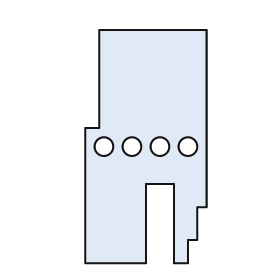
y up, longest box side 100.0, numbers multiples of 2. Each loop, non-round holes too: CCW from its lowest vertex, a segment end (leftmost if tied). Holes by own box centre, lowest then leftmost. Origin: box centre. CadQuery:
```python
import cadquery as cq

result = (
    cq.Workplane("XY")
    .moveTo(-26.0, -50.0)
    .lineTo(0.0, -50.0)
    .lineTo(0.0, -16.0)
    .lineTo(12.0, -16.0)
    .lineTo(12.0, -50.0)
    .lineTo(18.0, -50.0)
    .lineTo(18.0, -40.0)
    .lineTo(22.0, -40.0)
    .lineTo(22.0, -26.0)
    .lineTo(26.0, -26.0)
    .lineTo(26.0, 50.0)
    .lineTo(-20.0, 50.0)
    .lineTo(-20.0, 8.0)
    .lineTo(-26.0, 8.0)
    .close()
    .moveTo(-18.0, 0.0)
    .circle(4.0)
    .moveTo(-6.0, 0.0)
    .circle(4.0)
    .moveTo(6.0, 0.0)
    .circle(4.0)
    .moveTo(18.0, 0.0)
    .circle(4.0)
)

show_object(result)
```